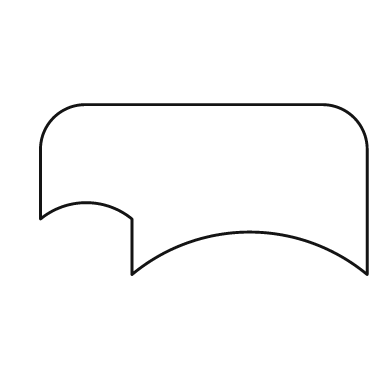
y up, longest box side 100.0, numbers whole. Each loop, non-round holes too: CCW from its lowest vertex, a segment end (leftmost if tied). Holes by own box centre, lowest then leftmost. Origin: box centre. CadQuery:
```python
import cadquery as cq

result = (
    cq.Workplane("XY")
    .moveTo(-22.0, -26.0)
    .threePointArc((14.0, -13.0), (50.0, -26.0))
    .lineTo(50.0, 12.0)
    .threePointArc((46.0, 22.0), (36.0, 26.0))
    .lineTo(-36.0, 26.0)
    .threePointArc((-46.0, 22.0), (-50.0, 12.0))
    .lineTo(-50.0, -9.0)
    .threePointArc((-36.0, -4.0), (-22.0, -9.0))
    .close()
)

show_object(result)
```